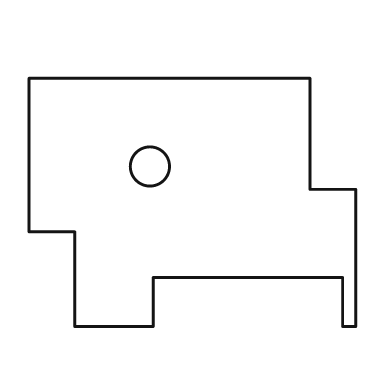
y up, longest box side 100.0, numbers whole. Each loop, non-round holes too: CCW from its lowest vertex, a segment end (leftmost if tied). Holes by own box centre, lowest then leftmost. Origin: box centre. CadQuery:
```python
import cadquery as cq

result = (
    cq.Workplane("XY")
    .moveTo(-36.0, -38.0)
    .lineTo(-12.0, -38.0)
    .lineTo(-12.0, -23.0)
    .lineTo(46.0, -23.0)
    .lineTo(46.0, -38.0)
    .lineTo(50.0, -38.0)
    .lineTo(50.0, 4.0)
    .lineTo(36.0, 4.0)
    .lineTo(36.0, 38.0)
    .lineTo(-50.0, 38.0)
    .lineTo(-50.0, -9.0)
    .lineTo(-36.0, -9.0)
    .close()
    .moveTo(-13.0, 11.0)
    .circle(6.0)
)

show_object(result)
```